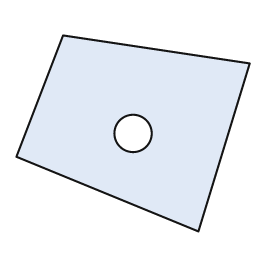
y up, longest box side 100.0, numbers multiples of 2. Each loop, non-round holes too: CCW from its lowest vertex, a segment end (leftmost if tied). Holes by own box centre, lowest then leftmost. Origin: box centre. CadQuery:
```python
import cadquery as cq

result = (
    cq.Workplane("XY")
    .moveTo(28.0, -42.0)
    .lineTo(50.0, 30.0)
    .lineTo(-30.0, 42.0)
    .lineTo(-50.0, -10.0)
    .close()
    .moveTo(0.0, 0.0)
    .circle(8.0)
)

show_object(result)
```